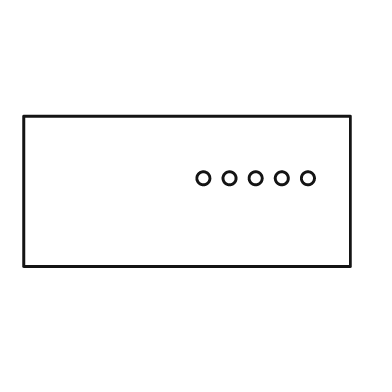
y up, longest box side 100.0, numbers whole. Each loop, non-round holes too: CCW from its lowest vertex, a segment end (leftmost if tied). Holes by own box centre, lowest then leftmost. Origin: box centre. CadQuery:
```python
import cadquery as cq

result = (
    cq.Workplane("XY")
    .moveTo(-50.0, -23.0)
    .lineTo(50.0, -23.0)
    .lineTo(50.0, 23.0)
    .lineTo(-50.0, 23.0)
    .close()
    .moveTo(5.0, 4.0)
    .circle(2.0)
    .moveTo(13.0, 4.0)
    .circle(2.0)
    .moveTo(21.0, 4.0)
    .circle(2.0)
    .moveTo(29.0, 4.0)
    .circle(2.0)
    .moveTo(37.0, 4.0)
    .circle(2.0)
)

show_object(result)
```